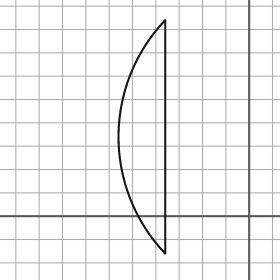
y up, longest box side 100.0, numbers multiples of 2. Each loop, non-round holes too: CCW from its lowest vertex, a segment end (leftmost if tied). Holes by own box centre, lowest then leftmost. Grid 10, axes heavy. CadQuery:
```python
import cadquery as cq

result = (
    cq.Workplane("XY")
    .moveTo(-36.0, -16.0)
    .lineTo(-36.0, 84.0)
    .threePointArc((-56.0, 34.0), (-36.0, -16.0))
    .close()
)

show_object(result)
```